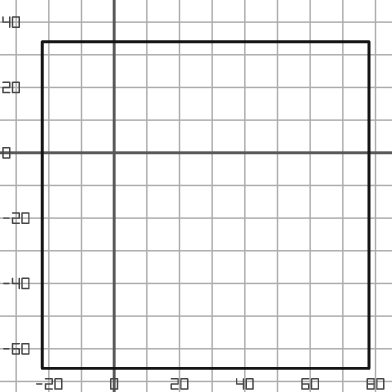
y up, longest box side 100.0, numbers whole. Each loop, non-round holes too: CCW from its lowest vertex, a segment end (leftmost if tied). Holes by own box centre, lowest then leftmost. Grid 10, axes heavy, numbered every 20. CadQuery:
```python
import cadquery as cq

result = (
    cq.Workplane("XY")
    .moveTo(-22.0, -66.0)
    .lineTo(78.0, -66.0)
    .lineTo(78.0, 34.0)
    .lineTo(-22.0, 34.0)
    .close()
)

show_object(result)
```